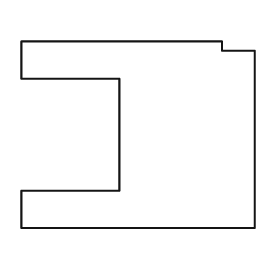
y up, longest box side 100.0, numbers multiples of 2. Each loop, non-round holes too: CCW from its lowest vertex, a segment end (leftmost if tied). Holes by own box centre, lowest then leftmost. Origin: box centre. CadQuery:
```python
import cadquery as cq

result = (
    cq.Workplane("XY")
    .moveTo(-50.0, -40.0)
    .lineTo(50.0, -40.0)
    .lineTo(50.0, 36.0)
    .lineTo(36.0, 36.0)
    .lineTo(36.0, 40.0)
    .lineTo(-50.0, 40.0)
    .lineTo(-50.0, 24.0)
    .lineTo(-8.0, 24.0)
    .lineTo(-8.0, -24.0)
    .lineTo(-50.0, -24.0)
    .close()
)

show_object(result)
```